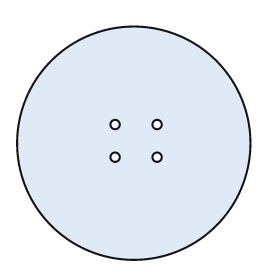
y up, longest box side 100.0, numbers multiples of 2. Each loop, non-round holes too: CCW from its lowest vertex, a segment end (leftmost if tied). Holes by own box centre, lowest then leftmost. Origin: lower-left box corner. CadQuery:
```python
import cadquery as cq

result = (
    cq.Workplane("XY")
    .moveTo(50.0, 50.0)
    .circle(50.0)
    .moveTo(42.0, 44.0)
    .circle(2.0)
    .moveTo(60.0, 44.0)
    .circle(2.0)
    .moveTo(42.0, 58.0)
    .circle(2.0)
    .moveTo(60.0, 58.0)
    .circle(2.0)
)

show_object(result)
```